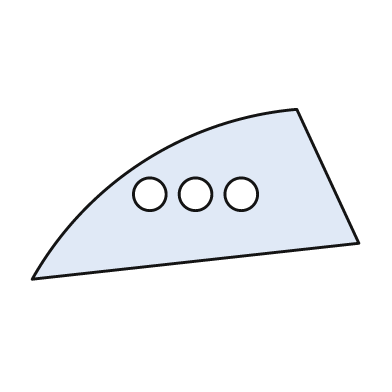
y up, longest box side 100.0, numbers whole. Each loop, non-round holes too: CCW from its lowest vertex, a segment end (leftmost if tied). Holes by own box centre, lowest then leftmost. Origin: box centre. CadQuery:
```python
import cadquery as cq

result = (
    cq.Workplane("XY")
    .moveTo(-50.0, -26.0)
    .lineTo(50.0, -15.0)
    .lineTo(31.0, 26.0)
    .threePointArc((-16.0, 10.0), (-50.0, -26.0))
    .close()
    .moveTo(-14.0, 0.0)
    .circle(5.0)
    .moveTo(0.0, 0.0)
    .circle(5.0)
    .moveTo(14.0, 0.0)
    .circle(5.0)
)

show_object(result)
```